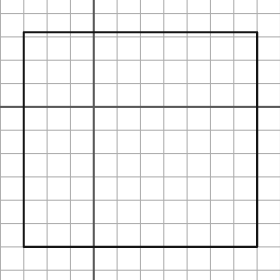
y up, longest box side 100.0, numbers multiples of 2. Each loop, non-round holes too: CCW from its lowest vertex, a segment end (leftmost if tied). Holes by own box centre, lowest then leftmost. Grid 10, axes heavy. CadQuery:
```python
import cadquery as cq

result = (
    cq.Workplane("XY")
    .moveTo(-30.0, -60.0)
    .lineTo(70.0, -60.0)
    .lineTo(70.0, 32.0)
    .lineTo(-30.0, 32.0)
    .close()
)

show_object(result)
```